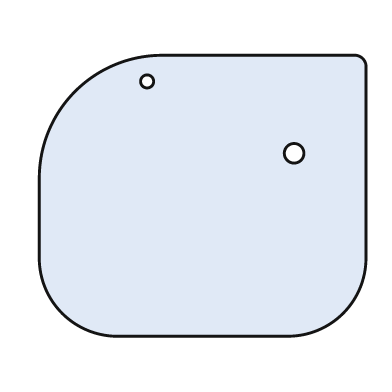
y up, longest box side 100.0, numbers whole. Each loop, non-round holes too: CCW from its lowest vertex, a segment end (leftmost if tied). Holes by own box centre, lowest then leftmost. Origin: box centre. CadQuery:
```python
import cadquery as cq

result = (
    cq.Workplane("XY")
    .moveTo(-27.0, -43.0)
    .lineTo(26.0, -43.0)
    .threePointArc((43.0, -36.0), (50.0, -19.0))
    .lineTo(50.0, 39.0)
    .threePointArc((49.0, 42.0), (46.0, 43.0))
    .lineTo(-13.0, 43.0)
    .threePointArc((-39.0, 32.0), (-50.0, 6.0))
    .lineTo(-50.0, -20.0)
    .threePointArc((-43.0, -36.0), (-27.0, -43.0))
    .close()
    .moveTo(28.0, 13.0)
    .circle(3.0)
    .moveTo(-17.0, 35.0)
    .circle(2.0)
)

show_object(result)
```